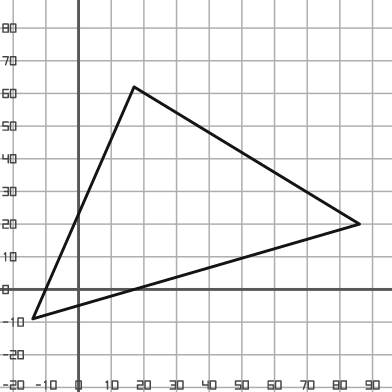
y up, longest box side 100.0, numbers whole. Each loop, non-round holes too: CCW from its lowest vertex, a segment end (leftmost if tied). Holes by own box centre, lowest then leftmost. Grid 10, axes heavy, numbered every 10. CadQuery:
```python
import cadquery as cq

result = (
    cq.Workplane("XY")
    .moveTo(-14.0, -9.0)
    .lineTo(86.0, 20.0)
    .lineTo(17.0, 62.0)
    .close()
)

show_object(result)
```